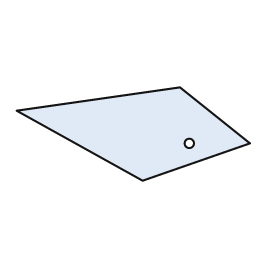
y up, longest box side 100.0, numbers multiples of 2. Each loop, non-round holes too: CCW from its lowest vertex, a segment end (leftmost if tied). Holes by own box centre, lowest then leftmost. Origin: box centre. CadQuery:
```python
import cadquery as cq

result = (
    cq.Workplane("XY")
    .moveTo(4.0, -20.0)
    .lineTo(50.0, -4.0)
    .lineTo(20.0, 20.0)
    .lineTo(-50.0, 10.0)
    .close()
    .moveTo(24.0, -4.0)
    .circle(2.0)
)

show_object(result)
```